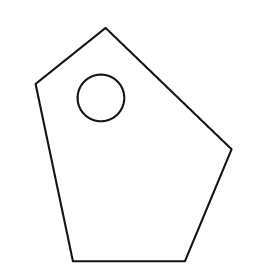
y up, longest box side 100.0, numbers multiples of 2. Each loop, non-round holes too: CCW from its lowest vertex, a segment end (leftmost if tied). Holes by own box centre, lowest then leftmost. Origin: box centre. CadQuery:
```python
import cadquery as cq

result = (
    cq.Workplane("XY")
    .moveTo(-26.0, -50.0)
    .lineTo(22.0, -50.0)
    .lineTo(42.0, -2.0)
    .lineTo(-12.0, 50.0)
    .lineTo(-42.0, 26.0)
    .close()
    .moveTo(-14.0, 20.0)
    .circle(10.0)
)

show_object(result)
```